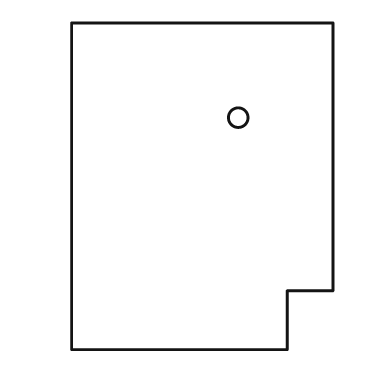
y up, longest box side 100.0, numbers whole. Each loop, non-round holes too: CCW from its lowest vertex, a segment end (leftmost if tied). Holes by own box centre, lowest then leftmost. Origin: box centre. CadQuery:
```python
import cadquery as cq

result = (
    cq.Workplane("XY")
    .moveTo(-40.0, -50.0)
    .lineTo(26.0, -50.0)
    .lineTo(26.0, -32.0)
    .lineTo(40.0, -32.0)
    .lineTo(40.0, 50.0)
    .lineTo(-40.0, 50.0)
    .close()
    .moveTo(11.0, 21.0)
    .circle(3.0)
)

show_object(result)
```